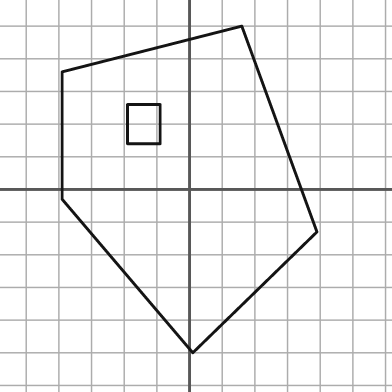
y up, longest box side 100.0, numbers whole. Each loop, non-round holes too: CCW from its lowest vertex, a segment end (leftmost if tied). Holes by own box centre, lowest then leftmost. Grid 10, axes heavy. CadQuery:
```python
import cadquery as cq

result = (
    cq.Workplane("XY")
    .moveTo(1.0, -50.0)
    .lineTo(39.0, -13.0)
    .lineTo(16.0, 50.0)
    .lineTo(-39.0, 36.0)
    .lineTo(-39.0, -3.0)
    .close()
    .moveTo(-19.0, 14.0)
    .lineTo(-9.0, 14.0)
    .lineTo(-9.0, 26.0)
    .lineTo(-19.0, 26.0)
    .close()
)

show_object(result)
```